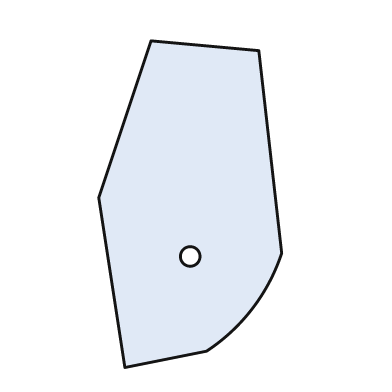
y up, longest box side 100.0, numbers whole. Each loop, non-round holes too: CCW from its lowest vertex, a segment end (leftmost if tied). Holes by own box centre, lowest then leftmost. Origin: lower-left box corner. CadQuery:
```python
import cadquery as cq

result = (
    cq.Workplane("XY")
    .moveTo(8.0, 0.0)
    .lineTo(33.0, 5.0)
    .threePointArc((47.0, 18.0), (56.0, 35.0))
    .lineTo(49.0, 97.0)
    .lineTo(16.0, 100.0)
    .lineTo(0.0, 52.0)
    .close()
    .moveTo(28.0, 34.0)
    .circle(3.0)
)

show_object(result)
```